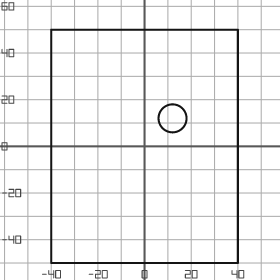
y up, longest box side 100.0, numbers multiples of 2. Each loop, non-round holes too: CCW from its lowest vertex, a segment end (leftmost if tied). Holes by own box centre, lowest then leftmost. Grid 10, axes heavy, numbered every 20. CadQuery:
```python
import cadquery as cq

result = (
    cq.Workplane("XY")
    .moveTo(-40.0, -50.0)
    .lineTo(40.0, -50.0)
    .lineTo(40.0, 50.0)
    .lineTo(-40.0, 50.0)
    .close()
    .moveTo(12.0, 12.0)
    .circle(6.0)
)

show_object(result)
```